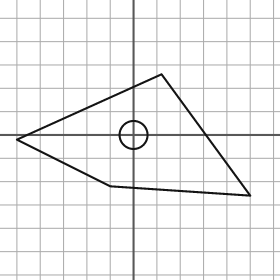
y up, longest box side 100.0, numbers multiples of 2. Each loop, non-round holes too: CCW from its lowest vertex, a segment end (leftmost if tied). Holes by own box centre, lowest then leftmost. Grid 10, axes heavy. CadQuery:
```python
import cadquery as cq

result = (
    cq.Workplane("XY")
    .moveTo(50.0, -26.0)
    .lineTo(12.0, 26.0)
    .lineTo(-50.0, -2.0)
    .lineTo(-10.0, -22.0)
    .close()
    .moveTo(0.0, 0.0)
    .circle(6.0)
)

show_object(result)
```